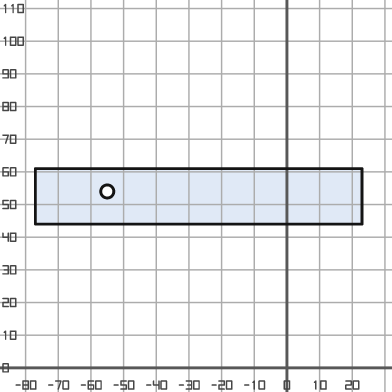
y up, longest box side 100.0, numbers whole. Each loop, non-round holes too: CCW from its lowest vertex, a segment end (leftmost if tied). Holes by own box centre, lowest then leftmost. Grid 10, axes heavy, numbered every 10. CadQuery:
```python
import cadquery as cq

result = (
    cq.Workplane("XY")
    .moveTo(-77.0, 44.0)
    .lineTo(23.0, 44.0)
    .lineTo(23.0, 61.0)
    .lineTo(-77.0, 61.0)
    .close()
    .moveTo(-55.0, 54.0)
    .circle(2.0)
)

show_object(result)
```